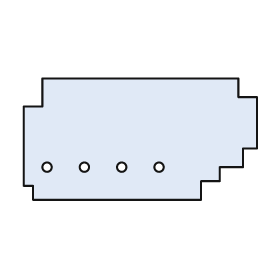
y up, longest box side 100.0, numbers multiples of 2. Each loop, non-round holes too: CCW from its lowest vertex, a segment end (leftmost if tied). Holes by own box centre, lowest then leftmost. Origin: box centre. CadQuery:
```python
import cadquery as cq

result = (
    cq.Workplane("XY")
    .moveTo(-46.0, -26.0)
    .lineTo(26.0, -26.0)
    .lineTo(26.0, -18.0)
    .lineTo(34.0, -18.0)
    .lineTo(34.0, -12.0)
    .lineTo(44.0, -12.0)
    .lineTo(44.0, -4.0)
    .lineTo(50.0, -4.0)
    .lineTo(50.0, 18.0)
    .lineTo(42.0, 18.0)
    .lineTo(42.0, 26.0)
    .lineTo(-42.0, 26.0)
    .lineTo(-42.0, 14.0)
    .lineTo(-50.0, 14.0)
    .lineTo(-50.0, -20.0)
    .lineTo(-46.0, -20.0)
    .close()
    .moveTo(-40.0, -12.0)
    .circle(2.0)
    .moveTo(-24.0, -12.0)
    .circle(2.0)
    .moveTo(-8.0, -12.0)
    .circle(2.0)
    .moveTo(8.0, -12.0)
    .circle(2.0)
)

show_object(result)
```